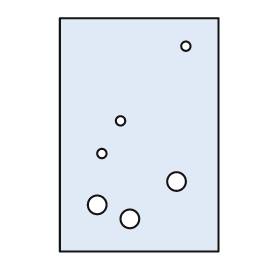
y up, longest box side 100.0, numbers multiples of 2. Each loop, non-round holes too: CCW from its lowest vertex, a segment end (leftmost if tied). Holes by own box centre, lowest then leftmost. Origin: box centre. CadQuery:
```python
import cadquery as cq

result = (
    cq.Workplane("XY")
    .moveTo(-34.0, -50.0)
    .lineTo(34.0, -50.0)
    .lineTo(34.0, 50.0)
    .lineTo(-34.0, 50.0)
    .close()
    .moveTo(-4.0, -36.0)
    .circle(4.0)
    .moveTo(-18.0, -30.0)
    .circle(4.0)
    .moveTo(16.0, -20.0)
    .circle(4.0)
    .moveTo(-16.0, -8.0)
    .circle(2.0)
    .moveTo(-8.0, 6.0)
    .circle(2.0)
    .moveTo(20.0, 38.0)
    .circle(2.0)
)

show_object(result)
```